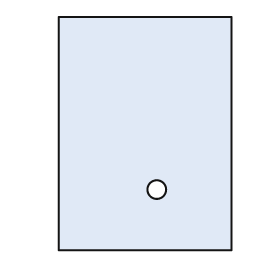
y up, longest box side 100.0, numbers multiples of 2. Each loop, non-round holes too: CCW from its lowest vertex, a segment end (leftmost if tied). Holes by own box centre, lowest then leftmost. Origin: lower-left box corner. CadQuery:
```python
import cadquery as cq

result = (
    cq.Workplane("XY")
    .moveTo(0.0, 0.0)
    .lineTo(74.0, 0.0)
    .lineTo(74.0, 100.0)
    .lineTo(0.0, 100.0)
    .close()
    .moveTo(42.0, 26.0)
    .circle(4.0)
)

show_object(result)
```